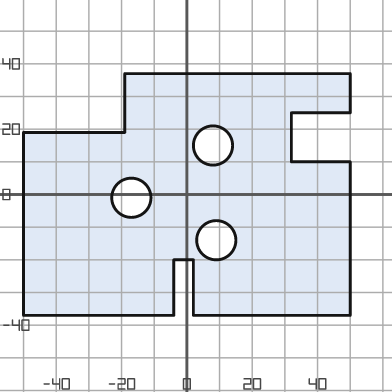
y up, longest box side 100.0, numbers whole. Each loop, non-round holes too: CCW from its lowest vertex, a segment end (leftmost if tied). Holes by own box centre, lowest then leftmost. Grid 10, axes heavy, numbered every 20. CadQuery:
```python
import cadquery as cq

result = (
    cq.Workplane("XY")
    .moveTo(-50.0, -37.0)
    .lineTo(-4.0, -37.0)
    .lineTo(-4.0, -20.0)
    .lineTo(2.0, -20.0)
    .lineTo(2.0, -37.0)
    .lineTo(50.0, -37.0)
    .lineTo(50.0, 10.0)
    .lineTo(32.0, 10.0)
    .lineTo(32.0, 25.0)
    .lineTo(50.0, 25.0)
    .lineTo(50.0, 37.0)
    .lineTo(-19.0, 37.0)
    .lineTo(-19.0, 19.0)
    .lineTo(-50.0, 19.0)
    .close()
    .moveTo(9.0, -14.0)
    .circle(6.0)
    .moveTo(-17.0, -1.0)
    .circle(6.0)
    .moveTo(8.0, 15.0)
    .circle(6.0)
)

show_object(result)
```